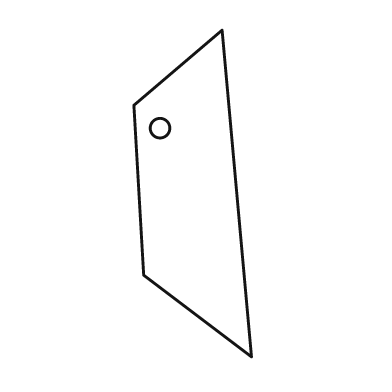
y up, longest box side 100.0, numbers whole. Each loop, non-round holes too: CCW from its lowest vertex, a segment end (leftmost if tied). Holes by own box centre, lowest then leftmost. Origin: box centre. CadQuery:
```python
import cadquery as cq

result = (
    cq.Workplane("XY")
    .moveTo(18.0, -50.0)
    .lineTo(9.0, 50.0)
    .lineTo(-18.0, 27.0)
    .lineTo(-15.0, -25.0)
    .close()
    .moveTo(-10.0, 20.0)
    .circle(3.0)
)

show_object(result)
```